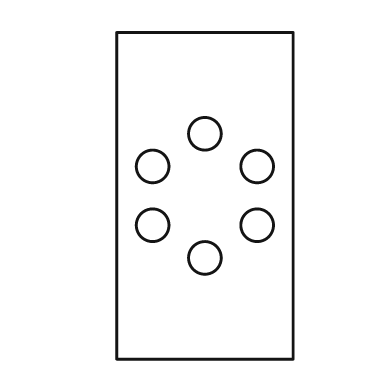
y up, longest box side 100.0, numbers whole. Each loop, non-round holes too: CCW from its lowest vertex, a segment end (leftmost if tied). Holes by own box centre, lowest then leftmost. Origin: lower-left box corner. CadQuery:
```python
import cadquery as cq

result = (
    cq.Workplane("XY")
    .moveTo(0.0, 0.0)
    .lineTo(54.0, 0.0)
    .lineTo(54.0, 100.0)
    .lineTo(0.0, 100.0)
    .close()
    .moveTo(27.0, 31.0)
    .circle(5.0)
    .moveTo(11.0, 41.0)
    .circle(5.0)
    .moveTo(43.0, 41.0)
    .circle(5.0)
    .moveTo(11.0, 59.0)
    .circle(5.0)
    .moveTo(43.0, 59.0)
    .circle(5.0)
    .moveTo(27.0, 69.0)
    .circle(5.0)
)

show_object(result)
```